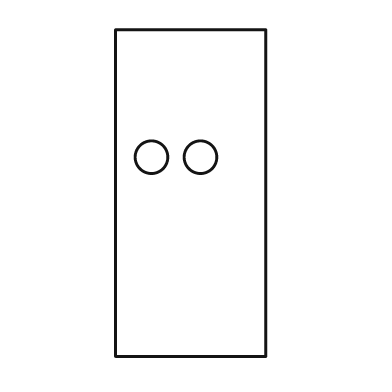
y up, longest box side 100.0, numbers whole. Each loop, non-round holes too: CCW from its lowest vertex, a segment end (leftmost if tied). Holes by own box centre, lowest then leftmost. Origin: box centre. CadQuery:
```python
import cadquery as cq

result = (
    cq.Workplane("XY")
    .moveTo(-23.0, -50.0)
    .lineTo(23.0, -50.0)
    .lineTo(23.0, 50.0)
    .lineTo(-23.0, 50.0)
    .close()
    .moveTo(-12.0, 11.0)
    .circle(5.0)
    .moveTo(3.0, 11.0)
    .circle(5.0)
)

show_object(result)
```